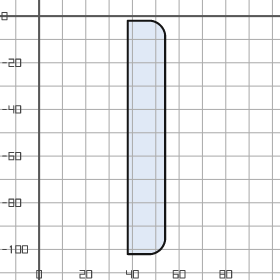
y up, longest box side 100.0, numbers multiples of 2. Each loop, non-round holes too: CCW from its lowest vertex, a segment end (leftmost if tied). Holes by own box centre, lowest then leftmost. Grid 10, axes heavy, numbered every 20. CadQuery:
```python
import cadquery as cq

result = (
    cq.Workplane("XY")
    .moveTo(38.0, -102.0)
    .lineTo(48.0, -102.0)
    .threePointArc((52.0, -100.0), (54.0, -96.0))
    .lineTo(54.0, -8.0)
    .threePointArc((52.0, -4.0), (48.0, -2.0))
    .lineTo(38.0, -2.0)
    .close()
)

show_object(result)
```